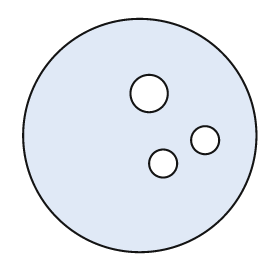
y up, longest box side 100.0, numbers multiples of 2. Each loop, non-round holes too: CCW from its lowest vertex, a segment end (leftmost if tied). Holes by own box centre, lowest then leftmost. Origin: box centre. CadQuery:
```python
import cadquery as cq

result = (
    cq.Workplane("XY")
    .moveTo(0.0, 0.0)
    .circle(50.0)
    .moveTo(10.0, -12.0)
    .circle(6.0)
    .moveTo(28.0, -2.0)
    .circle(6.0)
    .moveTo(4.0, 18.0)
    .circle(8.0)
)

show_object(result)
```